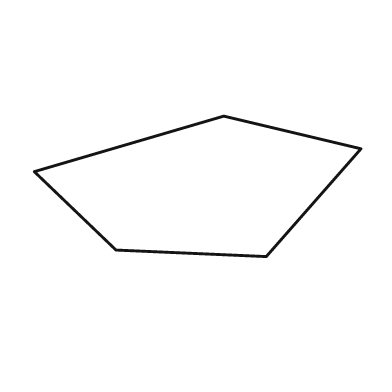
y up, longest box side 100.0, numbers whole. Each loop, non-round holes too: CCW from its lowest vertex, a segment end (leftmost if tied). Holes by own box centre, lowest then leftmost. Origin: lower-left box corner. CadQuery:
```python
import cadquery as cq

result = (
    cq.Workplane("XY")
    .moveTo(71.0, 0.0)
    .lineTo(100.0, 33.0)
    .lineTo(58.0, 43.0)
    .lineTo(0.0, 26.0)
    .lineTo(25.0, 2.0)
    .close()
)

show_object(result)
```